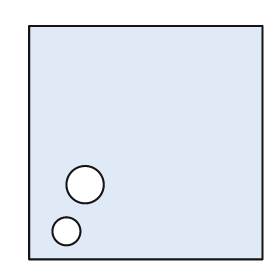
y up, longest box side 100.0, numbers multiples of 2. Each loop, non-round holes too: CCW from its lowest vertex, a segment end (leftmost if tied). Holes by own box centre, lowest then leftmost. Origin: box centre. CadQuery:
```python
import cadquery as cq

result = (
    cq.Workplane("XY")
    .moveTo(-50.0, -50.0)
    .lineTo(50.0, -50.0)
    .lineTo(50.0, 50.0)
    .lineTo(-50.0, 50.0)
    .close()
    .moveTo(-34.0, -38.0)
    .circle(6.0)
    .moveTo(-26.0, -18.0)
    .circle(8.0)
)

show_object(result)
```